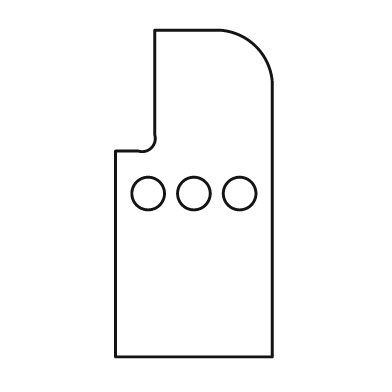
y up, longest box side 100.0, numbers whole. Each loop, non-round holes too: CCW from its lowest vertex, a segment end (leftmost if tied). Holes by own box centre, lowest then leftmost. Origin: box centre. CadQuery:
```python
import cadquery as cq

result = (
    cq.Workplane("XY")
    .moveTo(-24.0, -50.0)
    .lineTo(24.0, -50.0)
    .lineTo(24.0, 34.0)
    .threePointArc((19.0, 45.0), (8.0, 50.0))
    .lineTo(-12.0, 50.0)
    .lineTo(-12.0, 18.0)
    .threePointArc((-13.0, 14.0), (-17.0, 13.0))
    .lineTo(-24.0, 13.0)
    .close()
    .moveTo(-14.0, 0.0)
    .circle(5.0)
    .moveTo(0.0, 0.0)
    .circle(5.0)
    .moveTo(14.0, 0.0)
    .circle(5.0)
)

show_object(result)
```